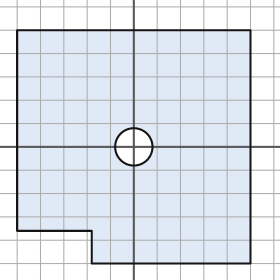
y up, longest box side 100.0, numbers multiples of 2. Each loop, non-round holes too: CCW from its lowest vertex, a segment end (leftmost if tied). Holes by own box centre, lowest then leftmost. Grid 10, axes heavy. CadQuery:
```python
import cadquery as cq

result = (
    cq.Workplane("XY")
    .moveTo(-18.0, -50.0)
    .lineTo(50.0, -50.0)
    .lineTo(50.0, 50.0)
    .lineTo(-50.0, 50.0)
    .lineTo(-50.0, -36.0)
    .lineTo(-18.0, -36.0)
    .close()
    .moveTo(0.0, 0.0)
    .circle(8.0)
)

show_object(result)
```